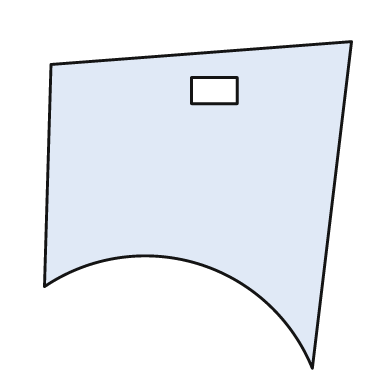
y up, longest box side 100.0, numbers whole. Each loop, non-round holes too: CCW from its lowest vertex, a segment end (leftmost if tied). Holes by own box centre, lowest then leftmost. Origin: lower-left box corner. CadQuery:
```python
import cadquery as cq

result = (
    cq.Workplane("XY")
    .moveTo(82.0, 0.0)
    .lineTo(94.0, 100.0)
    .lineTo(2.0, 93.0)
    .lineTo(0.0, 25.0)
    .threePointArc((47.0, 32.0), (82.0, 0.0))
    .close()
    .moveTo(45.0, 81.0)
    .lineTo(59.0, 81.0)
    .lineTo(59.0, 89.0)
    .lineTo(45.0, 89.0)
    .close()
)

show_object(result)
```